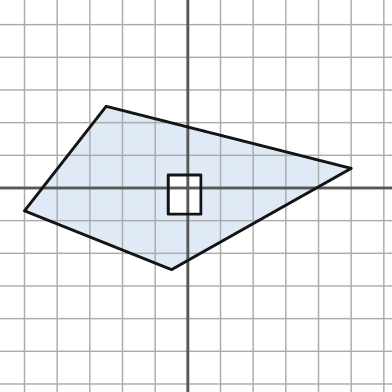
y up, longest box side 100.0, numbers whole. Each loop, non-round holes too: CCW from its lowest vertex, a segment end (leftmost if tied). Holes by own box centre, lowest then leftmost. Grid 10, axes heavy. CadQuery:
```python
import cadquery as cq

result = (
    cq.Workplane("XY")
    .moveTo(-5.0, -25.0)
    .lineTo(50.0, 6.0)
    .lineTo(-25.0, 25.0)
    .lineTo(-50.0, -7.0)
    .close()
    .moveTo(-6.0, -8.0)
    .lineTo(4.0, -8.0)
    .lineTo(4.0, 4.0)
    .lineTo(-6.0, 4.0)
    .close()
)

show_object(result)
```